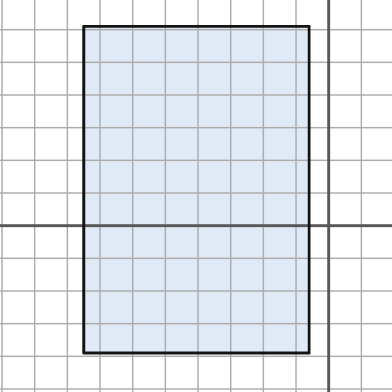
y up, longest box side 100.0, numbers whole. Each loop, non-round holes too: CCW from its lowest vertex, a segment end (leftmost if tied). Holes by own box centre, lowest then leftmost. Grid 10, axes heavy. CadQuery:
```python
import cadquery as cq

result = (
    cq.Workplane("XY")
    .moveTo(-75.0, -39.0)
    .lineTo(-6.0, -39.0)
    .lineTo(-6.0, 61.0)
    .lineTo(-75.0, 61.0)
    .close()
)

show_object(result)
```